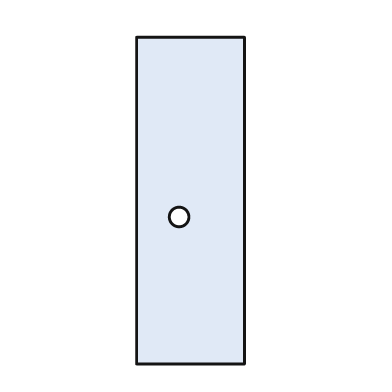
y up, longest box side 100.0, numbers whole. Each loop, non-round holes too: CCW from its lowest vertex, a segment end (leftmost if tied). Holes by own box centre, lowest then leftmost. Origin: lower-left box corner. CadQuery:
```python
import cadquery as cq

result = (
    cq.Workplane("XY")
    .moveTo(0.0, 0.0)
    .lineTo(33.0, 0.0)
    .lineTo(33.0, 100.0)
    .lineTo(0.0, 100.0)
    .close()
    .moveTo(13.0, 45.0)
    .circle(3.0)
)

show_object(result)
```